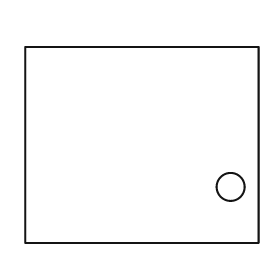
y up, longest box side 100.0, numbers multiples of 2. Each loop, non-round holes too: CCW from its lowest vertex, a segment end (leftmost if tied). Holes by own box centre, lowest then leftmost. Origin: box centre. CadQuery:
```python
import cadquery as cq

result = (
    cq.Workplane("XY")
    .moveTo(-50.0, -42.0)
    .lineTo(50.0, -42.0)
    .lineTo(50.0, 42.0)
    .lineTo(-50.0, 42.0)
    .close()
    .moveTo(38.0, -18.0)
    .circle(6.0)
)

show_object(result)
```